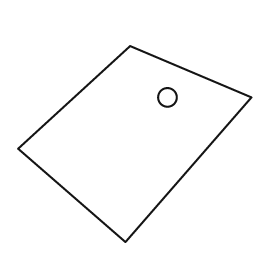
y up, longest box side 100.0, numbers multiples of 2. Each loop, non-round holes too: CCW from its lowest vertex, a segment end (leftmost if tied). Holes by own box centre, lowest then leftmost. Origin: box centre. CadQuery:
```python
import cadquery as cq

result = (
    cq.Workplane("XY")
    .moveTo(-4.0, -42.0)
    .lineTo(50.0, 20.0)
    .lineTo(-2.0, 42.0)
    .lineTo(-50.0, -2.0)
    .close()
    .moveTo(14.0, 20.0)
    .circle(4.0)
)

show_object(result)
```